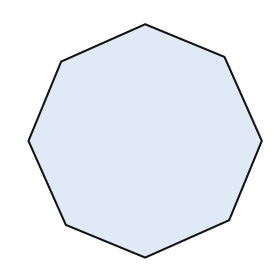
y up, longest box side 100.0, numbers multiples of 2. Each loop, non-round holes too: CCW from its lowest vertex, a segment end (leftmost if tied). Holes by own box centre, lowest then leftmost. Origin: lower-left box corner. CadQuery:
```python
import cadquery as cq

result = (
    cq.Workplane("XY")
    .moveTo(50.0, 0.0)
    .lineTo(86.0, 16.0)
    .lineTo(100.0, 50.0)
    .lineTo(84.0, 86.0)
    .lineTo(50.0, 100.0)
    .lineTo(14.0, 84.0)
    .lineTo(0.0, 50.0)
    .lineTo(16.0, 14.0)
    .close()
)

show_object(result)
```